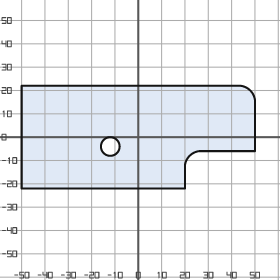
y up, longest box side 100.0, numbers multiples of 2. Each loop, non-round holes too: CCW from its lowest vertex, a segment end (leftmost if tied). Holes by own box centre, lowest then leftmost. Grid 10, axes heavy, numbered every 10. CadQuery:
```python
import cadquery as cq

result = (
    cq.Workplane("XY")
    .moveTo(-50.0, -22.0)
    .lineTo(20.0, -22.0)
    .lineTo(20.0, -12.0)
    .threePointArc((22.0, -8.0), (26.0, -6.0))
    .lineTo(50.0, -6.0)
    .lineTo(50.0, 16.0)
    .threePointArc((48.0, 20.0), (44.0, 22.0))
    .lineTo(-50.0, 22.0)
    .close()
    .moveTo(-12.0, -4.0)
    .circle(4.0)
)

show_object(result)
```